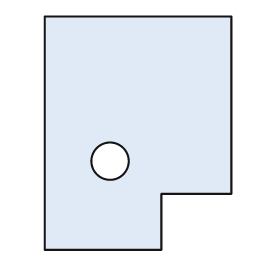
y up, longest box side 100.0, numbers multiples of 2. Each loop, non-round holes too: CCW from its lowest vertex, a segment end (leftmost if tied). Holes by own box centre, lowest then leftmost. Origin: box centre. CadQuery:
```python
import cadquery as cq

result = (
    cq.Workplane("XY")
    .moveTo(-40.0, -50.0)
    .lineTo(10.0, -50.0)
    .lineTo(10.0, -26.0)
    .lineTo(40.0, -26.0)
    .lineTo(40.0, 50.0)
    .lineTo(-40.0, 50.0)
    .close()
    .moveTo(-12.0, -12.0)
    .circle(8.0)
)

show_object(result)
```